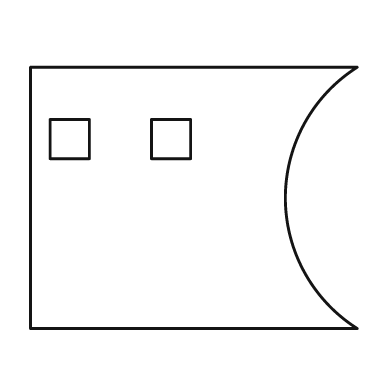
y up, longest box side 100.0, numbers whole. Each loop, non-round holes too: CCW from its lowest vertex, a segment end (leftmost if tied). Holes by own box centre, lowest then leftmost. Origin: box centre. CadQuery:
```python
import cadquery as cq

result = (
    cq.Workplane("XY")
    .moveTo(-50.0, -40.0)
    .lineTo(50.0, -40.0)
    .threePointArc((28.0, 0.0), (50.0, 40.0))
    .lineTo(-50.0, 40.0)
    .close()
    .moveTo(-44.0, 12.0)
    .lineTo(-32.0, 12.0)
    .lineTo(-32.0, 24.0)
    .lineTo(-44.0, 24.0)
    .close()
    .moveTo(-13.0, 12.0)
    .lineTo(-1.0, 12.0)
    .lineTo(-1.0, 24.0)
    .lineTo(-13.0, 24.0)
    .close()
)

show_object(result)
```